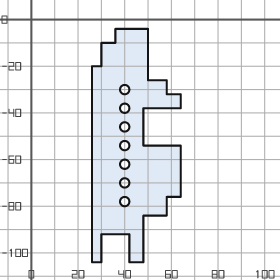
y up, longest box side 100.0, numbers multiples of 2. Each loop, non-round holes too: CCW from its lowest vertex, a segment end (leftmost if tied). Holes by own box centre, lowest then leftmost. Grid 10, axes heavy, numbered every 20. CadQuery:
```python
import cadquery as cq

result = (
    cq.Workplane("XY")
    .moveTo(26.0, -104.0)
    .lineTo(30.0, -104.0)
    .lineTo(30.0, -92.0)
    .lineTo(42.0, -92.0)
    .lineTo(42.0, -104.0)
    .lineTo(48.0, -104.0)
    .lineTo(48.0, -84.0)
    .lineTo(58.0, -84.0)
    .lineTo(58.0, -76.0)
    .lineTo(64.0, -76.0)
    .lineTo(64.0, -54.0)
    .lineTo(48.0, -54.0)
    .lineTo(48.0, -38.0)
    .lineTo(64.0, -38.0)
    .lineTo(64.0, -32.0)
    .lineTo(58.0, -32.0)
    .lineTo(58.0, -26.0)
    .lineTo(50.0, -26.0)
    .lineTo(50.0, -4.0)
    .lineTo(36.0, -4.0)
    .lineTo(36.0, -10.0)
    .lineTo(30.0, -10.0)
    .lineTo(30.0, -20.0)
    .lineTo(26.0, -20.0)
    .close()
    .moveTo(40.0, -78.0)
    .circle(2.0)
    .moveTo(40.0, -70.0)
    .circle(2.0)
    .moveTo(40.0, -62.0)
    .circle(2.0)
    .moveTo(40.0, -54.0)
    .circle(2.0)
    .moveTo(40.0, -46.0)
    .circle(2.0)
    .moveTo(40.0, -38.0)
    .circle(2.0)
    .moveTo(40.0, -30.0)
    .circle(2.0)
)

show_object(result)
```